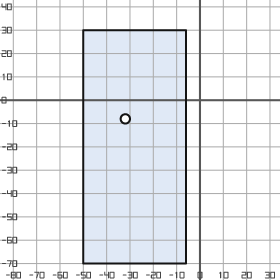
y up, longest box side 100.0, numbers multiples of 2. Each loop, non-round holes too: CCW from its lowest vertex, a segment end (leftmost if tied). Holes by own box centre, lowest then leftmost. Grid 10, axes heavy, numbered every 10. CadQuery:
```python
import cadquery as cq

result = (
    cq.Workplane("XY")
    .moveTo(-50.0, -70.0)
    .lineTo(-6.0, -70.0)
    .lineTo(-6.0, 30.0)
    .lineTo(-50.0, 30.0)
    .close()
    .moveTo(-32.0, -8.0)
    .circle(2.0)
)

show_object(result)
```